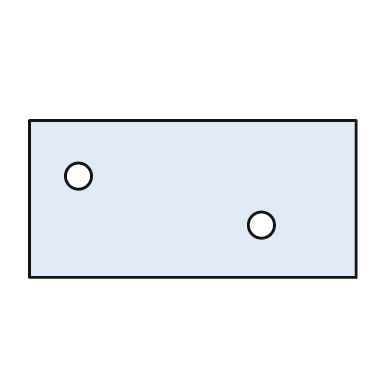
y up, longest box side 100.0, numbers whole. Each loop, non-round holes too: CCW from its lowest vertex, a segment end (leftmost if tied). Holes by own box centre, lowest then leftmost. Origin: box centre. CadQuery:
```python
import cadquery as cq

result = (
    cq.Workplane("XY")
    .moveTo(-50.0, -24.0)
    .lineTo(50.0, -24.0)
    .lineTo(50.0, 24.0)
    .lineTo(-50.0, 24.0)
    .close()
    .moveTo(21.0, -8.0)
    .circle(4.0)
    .moveTo(-35.0, 7.0)
    .circle(4.0)
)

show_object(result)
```